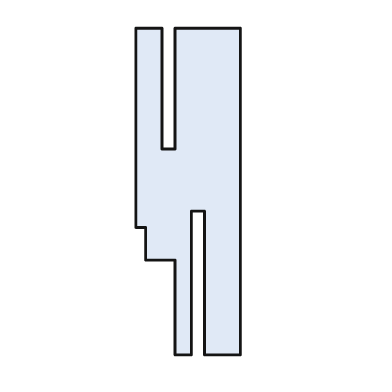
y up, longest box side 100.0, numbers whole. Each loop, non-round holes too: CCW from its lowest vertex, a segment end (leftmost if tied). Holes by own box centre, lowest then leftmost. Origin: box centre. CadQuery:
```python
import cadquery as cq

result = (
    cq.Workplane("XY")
    .moveTo(-4.0, -50.0)
    .lineTo(1.0, -50.0)
    .lineTo(1.0, -6.0)
    .lineTo(5.0, -6.0)
    .lineTo(5.0, -50.0)
    .lineTo(16.0, -50.0)
    .lineTo(16.0, 50.0)
    .lineTo(-4.0, 50.0)
    .lineTo(-4.0, 13.0)
    .lineTo(-8.0, 13.0)
    .lineTo(-8.0, 50.0)
    .lineTo(-16.0, 50.0)
    .lineTo(-16.0, -11.0)
    .lineTo(-13.0, -11.0)
    .lineTo(-13.0, -21.0)
    .lineTo(-4.0, -21.0)
    .close()
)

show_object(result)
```